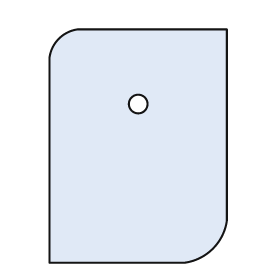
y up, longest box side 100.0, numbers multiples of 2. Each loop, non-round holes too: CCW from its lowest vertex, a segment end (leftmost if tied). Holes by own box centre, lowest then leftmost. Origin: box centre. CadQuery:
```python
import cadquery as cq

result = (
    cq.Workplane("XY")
    .moveTo(-38.0, -50.0)
    .lineTo(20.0, -50.0)
    .threePointArc((32.0, -44.0), (38.0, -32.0))
    .lineTo(38.0, 50.0)
    .lineTo(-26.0, 50.0)
    .threePointArc((-34.0, 46.0), (-38.0, 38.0))
    .close()
    .moveTo(0.0, 18.0)
    .circle(4.0)
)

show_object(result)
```